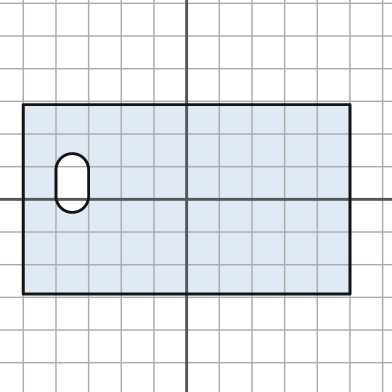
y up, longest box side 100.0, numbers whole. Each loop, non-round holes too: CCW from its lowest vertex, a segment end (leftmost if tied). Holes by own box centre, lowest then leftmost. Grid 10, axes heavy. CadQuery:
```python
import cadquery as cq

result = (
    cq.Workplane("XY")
    .moveTo(-50.0, -29.0)
    .lineTo(50.0, -29.0)
    .lineTo(50.0, 29.0)
    .lineTo(-50.0, 29.0)
    .close()
    .moveTo(-40.0, 1.0)
    .threePointArc((-35.0, -4.0), (-30.0, 1.0))
    .lineTo(-30.0, 9.0)
    .threePointArc((-35.0, 14.0), (-40.0, 9.0))
    .close()
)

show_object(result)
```